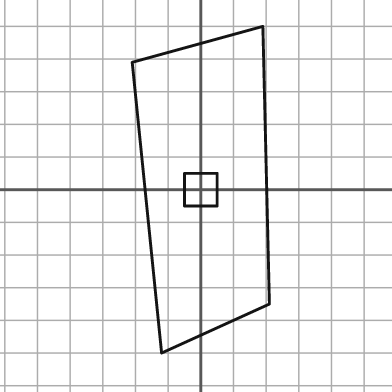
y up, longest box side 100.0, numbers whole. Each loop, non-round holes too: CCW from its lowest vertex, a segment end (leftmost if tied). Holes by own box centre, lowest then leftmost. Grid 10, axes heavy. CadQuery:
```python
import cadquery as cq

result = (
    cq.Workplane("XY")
    .moveTo(-12.0, -50.0)
    .lineTo(21.0, -35.0)
    .lineTo(19.0, 50.0)
    .lineTo(-21.0, 39.0)
    .close()
    .moveTo(-5.0, -5.0)
    .lineTo(5.0, -5.0)
    .lineTo(5.0, 5.0)
    .lineTo(-5.0, 5.0)
    .close()
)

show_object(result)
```